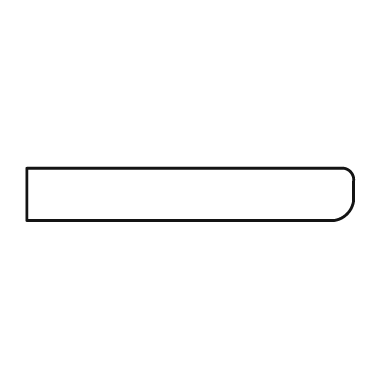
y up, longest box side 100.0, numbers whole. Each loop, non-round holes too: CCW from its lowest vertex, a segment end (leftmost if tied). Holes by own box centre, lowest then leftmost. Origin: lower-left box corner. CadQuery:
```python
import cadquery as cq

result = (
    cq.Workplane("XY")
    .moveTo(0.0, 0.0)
    .lineTo(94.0, 0.0)
    .threePointArc((98.0, 2.0), (100.0, 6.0))
    .lineTo(100.0, 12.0)
    .threePointArc((99.0, 15.0), (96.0, 16.0))
    .lineTo(0.0, 16.0)
    .close()
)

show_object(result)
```